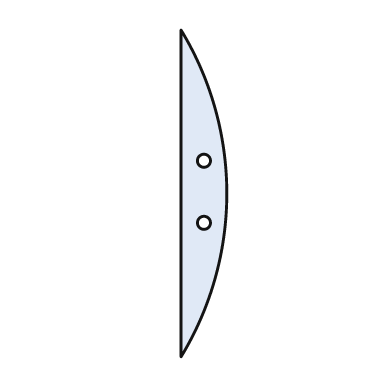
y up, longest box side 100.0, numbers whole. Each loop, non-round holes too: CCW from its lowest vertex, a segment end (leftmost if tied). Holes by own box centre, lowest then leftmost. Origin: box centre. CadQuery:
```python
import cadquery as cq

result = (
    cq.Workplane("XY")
    .moveTo(-7.0, -50.0)
    .threePointArc((7.0, 0.0), (-7.0, 50.0))
    .close()
    .moveTo(0.0, -9.0)
    .circle(2.0)
    .moveTo(0.0, 10.0)
    .circle(2.0)
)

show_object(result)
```